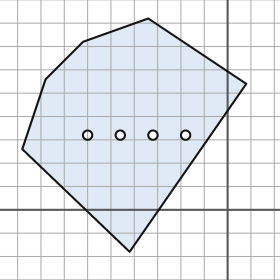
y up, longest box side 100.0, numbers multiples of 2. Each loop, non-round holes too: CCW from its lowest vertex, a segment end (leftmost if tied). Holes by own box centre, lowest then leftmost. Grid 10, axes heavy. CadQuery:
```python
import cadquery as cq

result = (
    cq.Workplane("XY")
    .moveTo(-42.0, -18.0)
    .lineTo(8.0, 54.0)
    .lineTo(-34.0, 82.0)
    .lineTo(-62.0, 72.0)
    .lineTo(-78.0, 56.0)
    .lineTo(-88.0, 26.0)
    .close()
    .moveTo(-60.0, 32.0)
    .circle(2.0)
    .moveTo(-46.0, 32.0)
    .circle(2.0)
    .moveTo(-32.0, 32.0)
    .circle(2.0)
    .moveTo(-18.0, 32.0)
    .circle(2.0)
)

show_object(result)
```